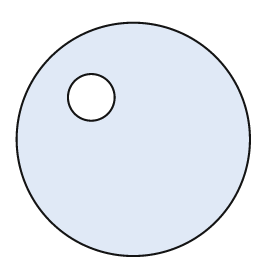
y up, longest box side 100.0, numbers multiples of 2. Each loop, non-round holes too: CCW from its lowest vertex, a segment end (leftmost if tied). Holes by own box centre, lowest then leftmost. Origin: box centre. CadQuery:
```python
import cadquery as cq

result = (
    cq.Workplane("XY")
    .moveTo(0.0, 0.0)
    .circle(50.0)
    .moveTo(-18.0, 18.0)
    .circle(10.0)
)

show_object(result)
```